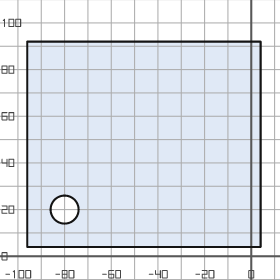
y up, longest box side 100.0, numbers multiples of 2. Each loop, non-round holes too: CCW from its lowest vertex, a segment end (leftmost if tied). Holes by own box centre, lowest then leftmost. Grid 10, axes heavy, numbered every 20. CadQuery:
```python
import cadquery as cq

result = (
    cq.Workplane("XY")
    .moveTo(-96.0, 4.0)
    .lineTo(4.0, 4.0)
    .lineTo(4.0, 92.0)
    .lineTo(-96.0, 92.0)
    .close()
    .moveTo(-80.0, 20.0)
    .circle(6.0)
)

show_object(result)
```